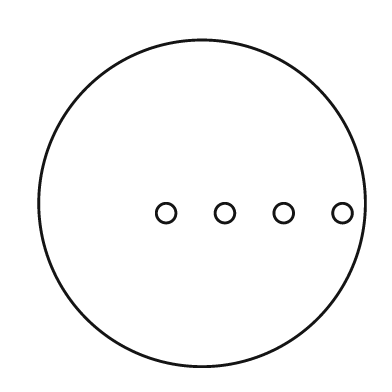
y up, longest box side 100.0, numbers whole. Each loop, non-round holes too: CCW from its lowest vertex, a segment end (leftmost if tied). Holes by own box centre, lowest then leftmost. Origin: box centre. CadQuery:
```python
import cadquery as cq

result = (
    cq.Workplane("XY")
    .moveTo(0.0, 0.0)
    .circle(50.0)
    .moveTo(-11.0, -3.0)
    .circle(3.0)
    .moveTo(7.0, -3.0)
    .circle(3.0)
    .moveTo(25.0, -3.0)
    .circle(3.0)
    .moveTo(43.0, -3.0)
    .circle(3.0)
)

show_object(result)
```